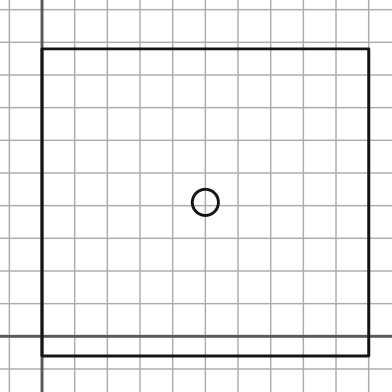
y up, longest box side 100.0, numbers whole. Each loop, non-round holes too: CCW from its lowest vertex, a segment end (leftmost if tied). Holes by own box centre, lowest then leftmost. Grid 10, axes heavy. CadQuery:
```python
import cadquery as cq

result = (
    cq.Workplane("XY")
    .moveTo(0.0, -6.0)
    .lineTo(100.0, -6.0)
    .lineTo(100.0, 88.0)
    .lineTo(0.0, 88.0)
    .close()
    .moveTo(50.0, 41.0)
    .circle(4.0)
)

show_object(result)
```